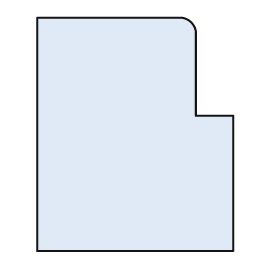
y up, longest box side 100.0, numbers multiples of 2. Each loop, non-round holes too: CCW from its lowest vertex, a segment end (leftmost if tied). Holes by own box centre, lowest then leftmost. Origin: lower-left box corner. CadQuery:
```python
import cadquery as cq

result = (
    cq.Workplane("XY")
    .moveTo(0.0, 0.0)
    .lineTo(84.0, 0.0)
    .lineTo(84.0, 58.0)
    .lineTo(68.0, 58.0)
    .lineTo(68.0, 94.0)
    .threePointArc((66.0, 98.0), (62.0, 100.0))
    .lineTo(0.0, 100.0)
    .close()
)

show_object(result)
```